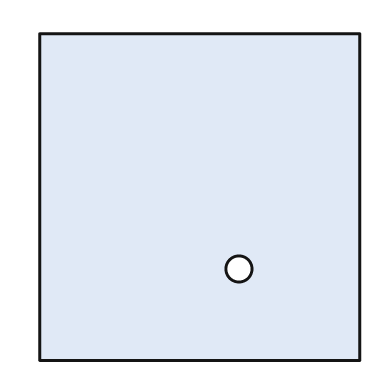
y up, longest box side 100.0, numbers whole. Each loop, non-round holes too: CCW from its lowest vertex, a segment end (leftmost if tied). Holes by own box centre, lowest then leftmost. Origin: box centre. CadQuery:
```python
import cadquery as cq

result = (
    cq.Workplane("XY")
    .moveTo(-49.0, -50.0)
    .lineTo(49.0, -50.0)
    .lineTo(49.0, 50.0)
    .lineTo(-49.0, 50.0)
    .close()
    .moveTo(12.0, -22.0)
    .circle(4.0)
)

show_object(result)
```